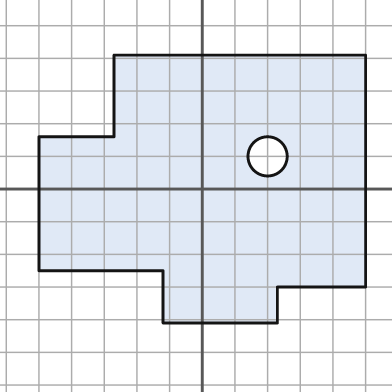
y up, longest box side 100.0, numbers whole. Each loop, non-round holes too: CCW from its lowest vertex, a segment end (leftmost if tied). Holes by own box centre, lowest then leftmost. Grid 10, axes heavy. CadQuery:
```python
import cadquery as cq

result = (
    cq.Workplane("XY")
    .moveTo(-12.0, -41.0)
    .lineTo(23.0, -41.0)
    .lineTo(23.0, -30.0)
    .lineTo(50.0, -30.0)
    .lineTo(50.0, 41.0)
    .lineTo(-27.0, 41.0)
    .lineTo(-27.0, 16.0)
    .lineTo(-50.0, 16.0)
    .lineTo(-50.0, -25.0)
    .lineTo(-12.0, -25.0)
    .close()
    .moveTo(20.0, 10.0)
    .circle(6.0)
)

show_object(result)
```